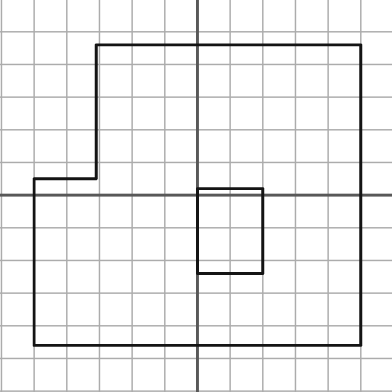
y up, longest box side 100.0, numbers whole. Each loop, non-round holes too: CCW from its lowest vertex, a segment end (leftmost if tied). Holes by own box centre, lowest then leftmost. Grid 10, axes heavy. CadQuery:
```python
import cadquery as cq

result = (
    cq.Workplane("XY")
    .moveTo(-50.0, -46.0)
    .lineTo(50.0, -46.0)
    .lineTo(50.0, 46.0)
    .lineTo(-31.0, 46.0)
    .lineTo(-31.0, 5.0)
    .lineTo(-50.0, 5.0)
    .close()
    .moveTo(0.0, -24.0)
    .lineTo(20.0, -24.0)
    .lineTo(20.0, 2.0)
    .lineTo(0.0, 2.0)
    .close()
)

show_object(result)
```